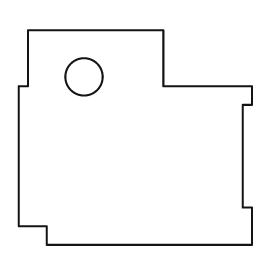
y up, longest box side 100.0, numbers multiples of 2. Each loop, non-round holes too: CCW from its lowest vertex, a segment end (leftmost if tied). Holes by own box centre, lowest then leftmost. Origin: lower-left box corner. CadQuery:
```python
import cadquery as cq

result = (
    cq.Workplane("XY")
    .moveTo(12.0, 0.0)
    .lineTo(100.0, 0.0)
    .lineTo(100.0, 16.0)
    .lineTo(96.0, 16.0)
    .lineTo(96.0, 60.0)
    .lineTo(100.0, 60.0)
    .lineTo(100.0, 68.0)
    .lineTo(62.0, 68.0)
    .lineTo(62.0, 92.0)
    .lineTo(4.0, 92.0)
    .lineTo(4.0, 68.0)
    .lineTo(0.0, 68.0)
    .lineTo(0.0, 8.0)
    .lineTo(12.0, 8.0)
    .close()
    .moveTo(28.0, 72.0)
    .circle(8.0)
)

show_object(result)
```